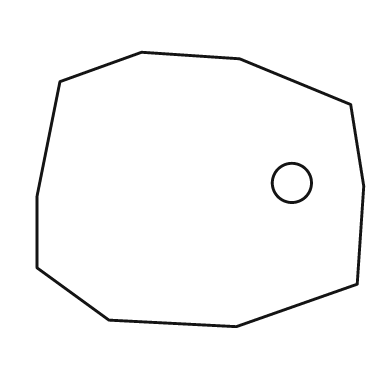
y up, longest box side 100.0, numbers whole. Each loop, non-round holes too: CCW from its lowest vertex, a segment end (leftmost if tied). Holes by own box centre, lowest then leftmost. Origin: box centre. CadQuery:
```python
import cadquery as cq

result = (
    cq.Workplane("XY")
    .moveTo(11.0, -42.0)
    .lineTo(48.0, -29.0)
    .lineTo(50.0, 1.0)
    .lineTo(46.0, 26.0)
    .lineTo(12.0, 40.0)
    .lineTo(-18.0, 42.0)
    .lineTo(-43.0, 33.0)
    .lineTo(-50.0, -2.0)
    .lineTo(-50.0, -24.0)
    .lineTo(-28.0, -40.0)
    .close()
    .moveTo(28.0, 2.0)
    .circle(6.0)
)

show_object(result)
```